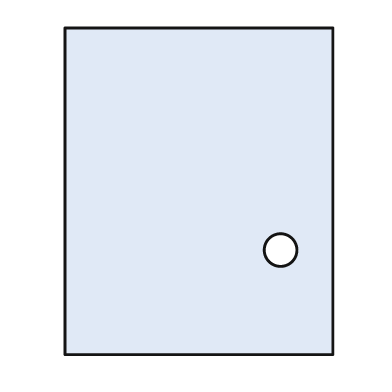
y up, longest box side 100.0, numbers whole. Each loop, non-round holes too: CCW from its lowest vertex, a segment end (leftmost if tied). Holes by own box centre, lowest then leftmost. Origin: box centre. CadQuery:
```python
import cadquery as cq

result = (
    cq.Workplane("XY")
    .moveTo(-41.0, -50.0)
    .lineTo(41.0, -50.0)
    .lineTo(41.0, 50.0)
    .lineTo(-41.0, 50.0)
    .close()
    .moveTo(25.0, -18.0)
    .circle(5.0)
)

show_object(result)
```